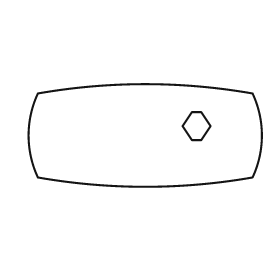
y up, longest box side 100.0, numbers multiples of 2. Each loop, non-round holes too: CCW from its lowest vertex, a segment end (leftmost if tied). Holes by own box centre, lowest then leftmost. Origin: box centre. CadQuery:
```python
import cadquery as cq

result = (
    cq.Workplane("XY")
    .moveTo(-46.0, -18.0)
    .threePointArc((0.0, -22.0), (46.0, -18.0))
    .threePointArc((50.0, 0.0), (46.0, 18.0))
    .threePointArc((0.0, 22.0), (-46.0, 18.0))
    .threePointArc((-50.0, 0.0), (-46.0, -18.0))
    .close()
    .moveTo(20.0, -2.0)
    .lineTo(24.0, -2.0)
    .lineTo(28.0, 4.0)
    .lineTo(24.0, 10.0)
    .lineTo(20.0, 10.0)
    .lineTo(16.0, 4.0)
    .close()
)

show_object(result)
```